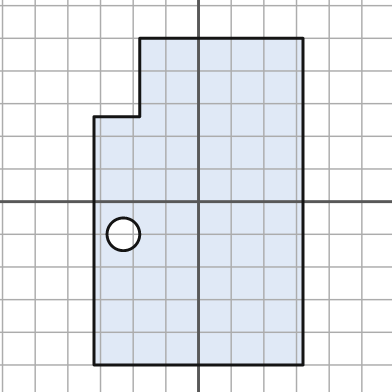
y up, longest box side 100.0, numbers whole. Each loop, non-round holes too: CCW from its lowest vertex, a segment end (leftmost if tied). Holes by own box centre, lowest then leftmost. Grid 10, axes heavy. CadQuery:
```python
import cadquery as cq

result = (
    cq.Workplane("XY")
    .moveTo(-32.0, -50.0)
    .lineTo(32.0, -50.0)
    .lineTo(32.0, 50.0)
    .lineTo(-18.0, 50.0)
    .lineTo(-18.0, 26.0)
    .lineTo(-32.0, 26.0)
    .close()
    .moveTo(-23.0, -10.0)
    .circle(5.0)
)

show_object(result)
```